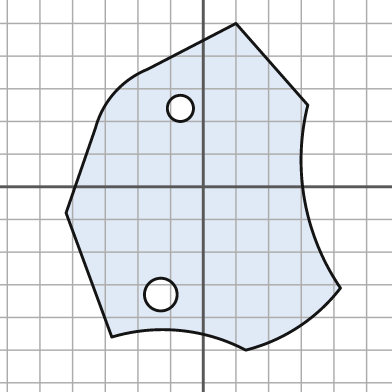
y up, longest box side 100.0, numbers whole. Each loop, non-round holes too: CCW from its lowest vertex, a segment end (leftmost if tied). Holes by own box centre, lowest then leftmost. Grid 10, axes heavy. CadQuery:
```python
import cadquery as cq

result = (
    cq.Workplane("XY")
    .moveTo(13.0, -50.0)
    .threePointArc((29.0, -43.0), (42.0, -31.0))
    .threePointArc((31.0, -4.0), (32.0, 25.0))
    .lineTo(10.0, 50.0)
    .lineTo(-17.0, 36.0)
    .threePointArc((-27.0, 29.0), (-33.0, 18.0))
    .lineTo(-42.0, -8.0)
    .lineTo(-28.0, -46.0)
    .threePointArc((-7.0, -44.0), (13.0, -50.0))
    .close()
    .moveTo(-13.0, -33.0)
    .circle(5.0)
    .moveTo(-7.0, 24.0)
    .circle(4.0)
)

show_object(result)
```